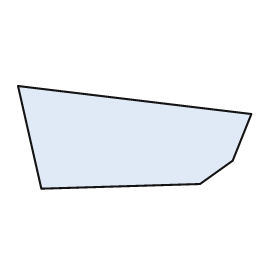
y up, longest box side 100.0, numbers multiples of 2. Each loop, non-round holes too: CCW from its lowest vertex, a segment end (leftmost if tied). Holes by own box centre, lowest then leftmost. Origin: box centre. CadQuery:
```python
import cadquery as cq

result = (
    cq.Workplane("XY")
    .moveTo(-40.0, -22.0)
    .lineTo(28.0, -20.0)
    .lineTo(42.0, -10.0)
    .lineTo(50.0, 10.0)
    .lineTo(-50.0, 22.0)
    .close()
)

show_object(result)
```